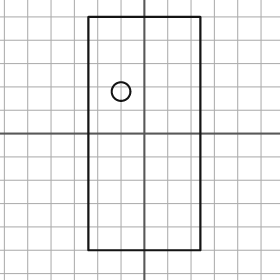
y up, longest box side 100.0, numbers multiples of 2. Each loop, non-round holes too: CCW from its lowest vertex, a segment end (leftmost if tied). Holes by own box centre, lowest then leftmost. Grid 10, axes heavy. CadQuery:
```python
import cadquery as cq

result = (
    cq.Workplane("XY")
    .moveTo(-24.0, -50.0)
    .lineTo(24.0, -50.0)
    .lineTo(24.0, 50.0)
    .lineTo(-24.0, 50.0)
    .close()
    .moveTo(-10.0, 18.0)
    .circle(4.0)
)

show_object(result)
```